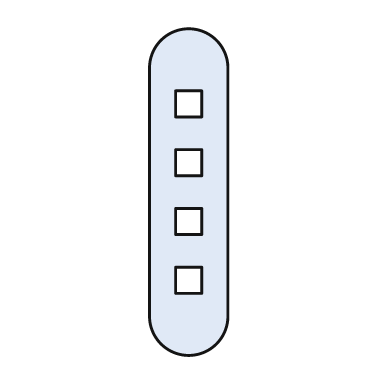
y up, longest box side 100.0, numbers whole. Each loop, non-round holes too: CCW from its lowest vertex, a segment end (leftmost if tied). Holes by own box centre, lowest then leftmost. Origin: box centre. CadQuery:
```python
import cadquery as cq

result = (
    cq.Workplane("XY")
    .moveTo(-12.0, -38.0)
    .threePointArc((0.0, -50.0), (12.0, -38.0))
    .lineTo(12.0, 38.0)
    .threePointArc((0.0, 50.0), (-12.0, 38.0))
    .close()
    .moveTo(-4.0, -31.0)
    .lineTo(4.0, -31.0)
    .lineTo(4.0, -23.0)
    .lineTo(-4.0, -23.0)
    .close()
    .moveTo(-4.0, -13.0)
    .lineTo(4.0, -13.0)
    .lineTo(4.0, -5.0)
    .lineTo(-4.0, -5.0)
    .close()
    .moveTo(-4.0, 5.0)
    .lineTo(4.0, 5.0)
    .lineTo(4.0, 13.0)
    .lineTo(-4.0, 13.0)
    .close()
    .moveTo(-4.0, 23.0)
    .lineTo(4.0, 23.0)
    .lineTo(4.0, 31.0)
    .lineTo(-4.0, 31.0)
    .close()
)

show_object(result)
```